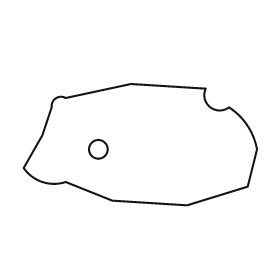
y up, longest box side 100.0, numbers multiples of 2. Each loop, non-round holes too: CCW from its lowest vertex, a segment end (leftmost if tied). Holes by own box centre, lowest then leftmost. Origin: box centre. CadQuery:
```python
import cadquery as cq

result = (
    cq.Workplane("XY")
    .moveTo(20.0, -26.0)
    .lineTo(46.0, -18.0)
    .lineTo(50.0, -2.0)
    .threePointArc((46.0, 8.0), (38.0, 16.0))
    .threePointArc((30.0, 16.0), (28.0, 24.0))
    .lineTo(-4.0, 26.0)
    .lineTo(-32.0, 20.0)
    .threePointArc((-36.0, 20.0), (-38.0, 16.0))
    .lineTo(-42.0, 4.0)
    .lineTo(-50.0, -10.0)
    .threePointArc((-42.0, -16.0), (-32.0, -16.0))
    .lineTo(-12.0, -24.0)
    .close()
    .moveTo(-18.0, -2.0)
    .circle(4.0)
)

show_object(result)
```